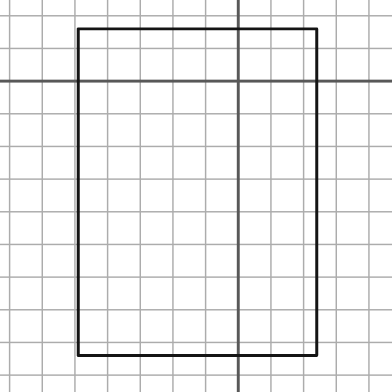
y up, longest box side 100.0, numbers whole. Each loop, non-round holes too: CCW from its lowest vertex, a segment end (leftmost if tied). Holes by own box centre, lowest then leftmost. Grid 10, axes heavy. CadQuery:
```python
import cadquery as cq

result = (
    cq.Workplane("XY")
    .moveTo(-49.0, -84.0)
    .lineTo(24.0, -84.0)
    .lineTo(24.0, 16.0)
    .lineTo(-49.0, 16.0)
    .close()
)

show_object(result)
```